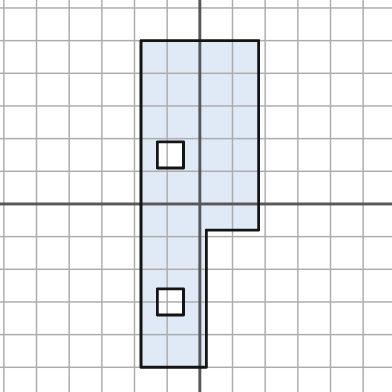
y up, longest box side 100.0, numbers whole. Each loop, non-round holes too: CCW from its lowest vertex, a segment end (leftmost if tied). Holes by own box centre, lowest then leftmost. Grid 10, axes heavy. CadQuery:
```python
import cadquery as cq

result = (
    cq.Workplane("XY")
    .moveTo(-18.0, -50.0)
    .lineTo(2.0, -50.0)
    .lineTo(2.0, -8.0)
    .lineTo(18.0, -8.0)
    .lineTo(18.0, 50.0)
    .lineTo(-18.0, 50.0)
    .close()
    .moveTo(-13.0, -34.0)
    .lineTo(-5.0, -34.0)
    .lineTo(-5.0, -26.0)
    .lineTo(-13.0, -26.0)
    .close()
    .moveTo(-13.0, 11.0)
    .lineTo(-5.0, 11.0)
    .lineTo(-5.0, 19.0)
    .lineTo(-13.0, 19.0)
    .close()
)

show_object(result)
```